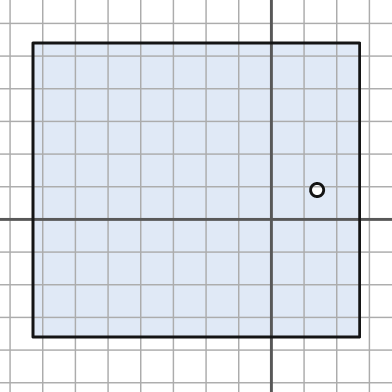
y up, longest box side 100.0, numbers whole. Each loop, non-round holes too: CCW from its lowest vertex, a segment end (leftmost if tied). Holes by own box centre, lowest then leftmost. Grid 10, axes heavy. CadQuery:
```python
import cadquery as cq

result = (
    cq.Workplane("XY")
    .moveTo(-73.0, -36.0)
    .lineTo(27.0, -36.0)
    .lineTo(27.0, 54.0)
    .lineTo(-73.0, 54.0)
    .close()
    .moveTo(14.0, 9.0)
    .circle(2.0)
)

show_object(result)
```